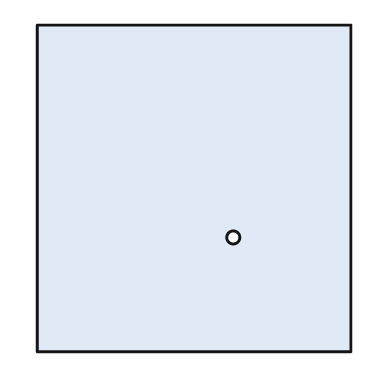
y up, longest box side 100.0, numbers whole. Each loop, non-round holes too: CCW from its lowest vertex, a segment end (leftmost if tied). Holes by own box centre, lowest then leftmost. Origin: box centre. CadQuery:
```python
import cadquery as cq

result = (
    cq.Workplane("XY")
    .moveTo(-48.0, -50.0)
    .lineTo(48.0, -50.0)
    .lineTo(48.0, 50.0)
    .lineTo(-48.0, 50.0)
    .close()
    .moveTo(12.0, -15.0)
    .circle(2.0)
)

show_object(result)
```